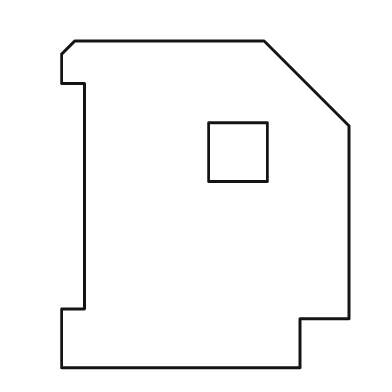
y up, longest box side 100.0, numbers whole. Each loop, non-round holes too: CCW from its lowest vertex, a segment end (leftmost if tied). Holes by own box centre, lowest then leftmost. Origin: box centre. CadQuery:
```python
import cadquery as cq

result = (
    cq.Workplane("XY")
    .moveTo(-44.0, -50.0)
    .lineTo(29.0, -50.0)
    .lineTo(29.0, -35.0)
    .lineTo(44.0, -35.0)
    .lineTo(44.0, 24.0)
    .lineTo(18.0, 50.0)
    .lineTo(-40.0, 50.0)
    .lineTo(-44.0, 46.0)
    .lineTo(-44.0, 37.0)
    .lineTo(-37.0, 37.0)
    .lineTo(-37.0, -32.0)
    .lineTo(-44.0, -32.0)
    .close()
    .moveTo(1.0, 7.0)
    .lineTo(19.0, 7.0)
    .lineTo(19.0, 25.0)
    .lineTo(1.0, 25.0)
    .close()
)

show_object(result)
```